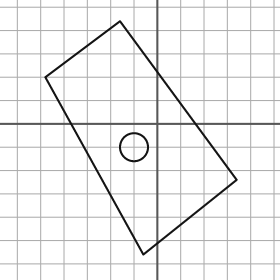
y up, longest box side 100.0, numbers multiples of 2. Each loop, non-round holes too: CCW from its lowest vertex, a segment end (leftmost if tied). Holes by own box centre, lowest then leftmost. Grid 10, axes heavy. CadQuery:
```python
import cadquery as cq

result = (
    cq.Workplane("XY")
    .moveTo(-6.0, -56.0)
    .lineTo(34.0, -24.0)
    .lineTo(-16.0, 44.0)
    .lineTo(-48.0, 20.0)
    .close()
    .moveTo(-10.0, -10.0)
    .circle(6.0)
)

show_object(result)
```